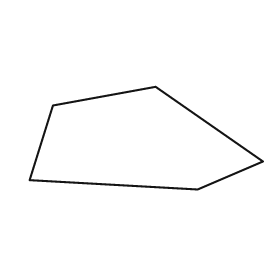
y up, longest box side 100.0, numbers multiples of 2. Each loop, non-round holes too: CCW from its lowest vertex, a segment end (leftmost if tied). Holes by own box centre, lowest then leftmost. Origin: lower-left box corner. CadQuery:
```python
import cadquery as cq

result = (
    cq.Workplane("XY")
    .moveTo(72.0, 0.0)
    .lineTo(100.0, 12.0)
    .lineTo(54.0, 44.0)
    .lineTo(10.0, 36.0)
    .lineTo(0.0, 4.0)
    .close()
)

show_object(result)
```